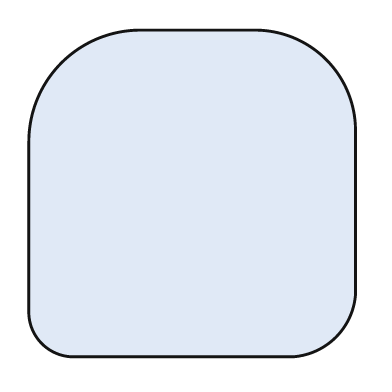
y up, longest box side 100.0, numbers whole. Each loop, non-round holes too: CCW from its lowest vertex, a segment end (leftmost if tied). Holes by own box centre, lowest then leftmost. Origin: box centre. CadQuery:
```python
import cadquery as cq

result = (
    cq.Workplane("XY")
    .moveTo(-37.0, -50.0)
    .lineTo(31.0, -50.0)
    .threePointArc((44.0, -44.0), (50.0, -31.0))
    .lineTo(50.0, 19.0)
    .threePointArc((41.0, 41.0), (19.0, 50.0))
    .lineTo(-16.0, 50.0)
    .threePointArc((-40.0, 40.0), (-50.0, 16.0))
    .lineTo(-50.0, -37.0)
    .threePointArc((-46.0, -46.0), (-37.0, -50.0))
    .close()
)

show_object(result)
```